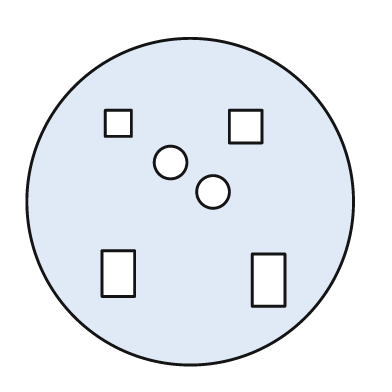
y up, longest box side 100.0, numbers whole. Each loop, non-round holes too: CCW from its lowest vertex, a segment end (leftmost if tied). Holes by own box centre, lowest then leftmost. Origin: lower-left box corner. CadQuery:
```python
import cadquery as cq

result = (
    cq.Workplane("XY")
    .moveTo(50.0, 50.0)
    .circle(50.0)
    .moveTo(69.0, 18.0)
    .lineTo(79.0, 18.0)
    .lineTo(79.0, 34.0)
    .lineTo(69.0, 34.0)
    .close()
    .moveTo(23.0, 21.0)
    .lineTo(33.0, 21.0)
    .lineTo(33.0, 35.0)
    .lineTo(23.0, 35.0)
    .close()
    .moveTo(57.0, 53.0)
    .circle(5.0)
    .moveTo(44.0, 62.0)
    .circle(5.0)
    .moveTo(62.0, 68.0)
    .lineTo(72.0, 68.0)
    .lineTo(72.0, 78.0)
    .lineTo(62.0, 78.0)
    .close()
    .moveTo(24.0, 70.0)
    .lineTo(32.0, 70.0)
    .lineTo(32.0, 78.0)
    .lineTo(24.0, 78.0)
    .close()
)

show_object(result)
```